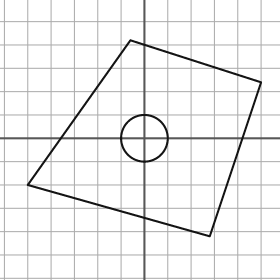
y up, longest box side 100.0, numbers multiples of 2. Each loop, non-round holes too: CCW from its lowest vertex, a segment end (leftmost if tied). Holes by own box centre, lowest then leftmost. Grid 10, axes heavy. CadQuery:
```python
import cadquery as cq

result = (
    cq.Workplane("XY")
    .moveTo(28.0, -42.0)
    .lineTo(50.0, 24.0)
    .lineTo(-6.0, 42.0)
    .lineTo(-50.0, -20.0)
    .close()
    .moveTo(0.0, 0.0)
    .circle(10.0)
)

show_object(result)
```